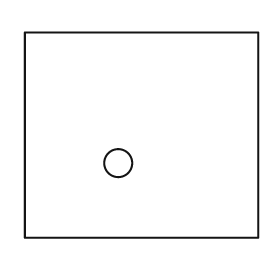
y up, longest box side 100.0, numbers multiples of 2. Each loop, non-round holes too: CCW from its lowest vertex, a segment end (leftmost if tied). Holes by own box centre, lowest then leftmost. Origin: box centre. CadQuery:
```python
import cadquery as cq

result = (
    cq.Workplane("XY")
    .moveTo(-50.0, -44.0)
    .lineTo(50.0, -44.0)
    .lineTo(50.0, 44.0)
    .lineTo(-50.0, 44.0)
    .close()
    .moveTo(-10.0, -12.0)
    .circle(6.0)
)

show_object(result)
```